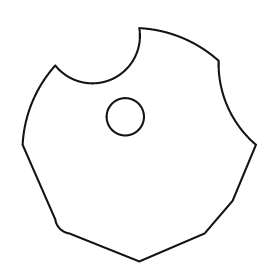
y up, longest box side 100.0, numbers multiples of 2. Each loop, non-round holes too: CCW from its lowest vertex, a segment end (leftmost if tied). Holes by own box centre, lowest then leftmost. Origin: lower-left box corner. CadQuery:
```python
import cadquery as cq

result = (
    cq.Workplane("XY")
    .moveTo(50.0, 0.0)
    .lineTo(78.0, 12.0)
    .lineTo(90.0, 26.0)
    .lineTo(100.0, 50.0)
    .threePointArc((88.0, 66.0), (84.0, 86.0))
    .threePointArc((68.0, 96.0), (50.0, 100.0))
    .threePointArc((38.0, 78.0), (14.0, 84.0))
    .threePointArc((4.0, 68.0), (0.0, 50.0))
    .lineTo(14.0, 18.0)
    .threePointArc((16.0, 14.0), (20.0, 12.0))
    .close()
    .moveTo(44.0, 62.0)
    .circle(8.0)
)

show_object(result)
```